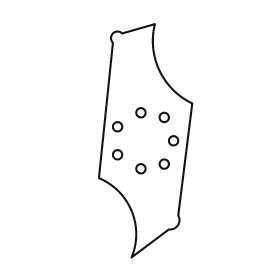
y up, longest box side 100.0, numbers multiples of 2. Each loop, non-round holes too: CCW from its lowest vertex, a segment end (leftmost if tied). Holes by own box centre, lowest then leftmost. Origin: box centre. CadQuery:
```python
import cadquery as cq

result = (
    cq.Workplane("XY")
    .moveTo(-6.0, -50.0)
    .lineTo(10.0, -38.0)
    .threePointArc((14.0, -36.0), (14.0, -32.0))
    .lineTo(20.0, 16.0)
    .threePointArc((6.0, 30.0), (4.0, 50.0))
    .lineTo(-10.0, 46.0)
    .threePointArc((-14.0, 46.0), (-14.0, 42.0))
    .lineTo(-20.0, -16.0)
    .threePointArc((-6.0, -30.0), (-6.0, -50.0))
    .close()
    .moveTo(-2.0, -12.0)
    .circle(2.0)
    .moveTo(8.0, -10.0)
    .circle(2.0)
    .moveTo(-12.0, -6.0)
    .circle(2.0)
    .moveTo(12.0, 0.0)
    .circle(2.0)
    .moveTo(-12.0, 6.0)
    .circle(2.0)
    .moveTo(8.0, 10.0)
    .circle(2.0)
    .moveTo(-2.0, 12.0)
    .circle(2.0)
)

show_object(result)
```